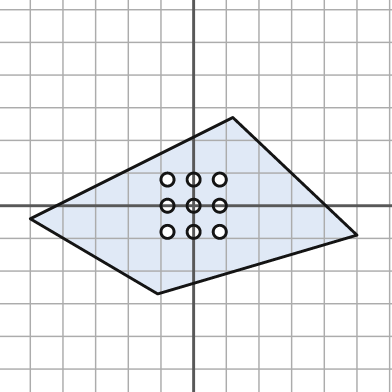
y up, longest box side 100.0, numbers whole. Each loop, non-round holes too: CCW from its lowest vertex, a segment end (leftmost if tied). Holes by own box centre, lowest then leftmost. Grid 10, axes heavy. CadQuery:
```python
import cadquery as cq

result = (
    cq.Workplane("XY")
    .moveTo(-11.0, -27.0)
    .lineTo(50.0, -9.0)
    .lineTo(12.0, 27.0)
    .lineTo(-50.0, -4.0)
    .close()
    .moveTo(-8.0, -8.0)
    .circle(2.0)
    .moveTo(0.0, -8.0)
    .circle(2.0)
    .moveTo(8.0, -8.0)
    .circle(2.0)
    .moveTo(-8.0, 0.0)
    .circle(2.0)
    .moveTo(0.0, 0.0)
    .circle(2.0)
    .moveTo(8.0, 0.0)
    .circle(2.0)
    .moveTo(-8.0, 8.0)
    .circle(2.0)
    .moveTo(0.0, 8.0)
    .circle(2.0)
    .moveTo(8.0, 8.0)
    .circle(2.0)
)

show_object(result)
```